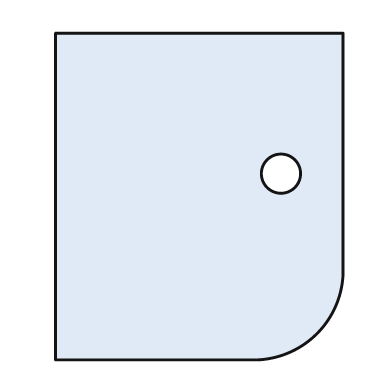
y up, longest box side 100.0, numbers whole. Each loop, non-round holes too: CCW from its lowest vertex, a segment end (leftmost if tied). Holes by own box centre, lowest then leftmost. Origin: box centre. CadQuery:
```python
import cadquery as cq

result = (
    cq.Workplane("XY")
    .moveTo(-44.0, -50.0)
    .lineTo(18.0, -50.0)
    .threePointArc((36.0, -42.0), (44.0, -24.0))
    .lineTo(44.0, 50.0)
    .lineTo(-44.0, 50.0)
    .close()
    .moveTo(25.0, 7.0)
    .circle(6.0)
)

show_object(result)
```